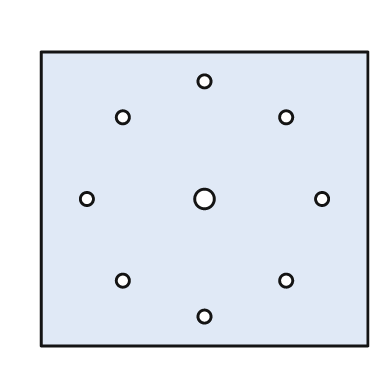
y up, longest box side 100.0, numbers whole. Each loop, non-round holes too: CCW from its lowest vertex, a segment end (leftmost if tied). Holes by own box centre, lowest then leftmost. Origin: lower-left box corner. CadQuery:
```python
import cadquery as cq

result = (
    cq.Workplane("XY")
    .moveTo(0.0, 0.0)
    .lineTo(100.0, 0.0)
    .lineTo(100.0, 90.0)
    .lineTo(0.0, 90.0)
    .close()
    .moveTo(50.0, 9.0)
    .circle(2.0)
    .moveTo(25.0, 20.0)
    .circle(2.0)
    .moveTo(75.0, 20.0)
    .circle(2.0)
    .moveTo(14.0, 45.0)
    .circle(2.0)
    .moveTo(50.0, 45.0)
    .circle(3.0)
    .moveTo(86.0, 45.0)
    .circle(2.0)
    .moveTo(25.0, 70.0)
    .circle(2.0)
    .moveTo(75.0, 70.0)
    .circle(2.0)
    .moveTo(50.0, 81.0)
    .circle(2.0)
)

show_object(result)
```